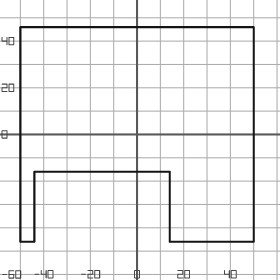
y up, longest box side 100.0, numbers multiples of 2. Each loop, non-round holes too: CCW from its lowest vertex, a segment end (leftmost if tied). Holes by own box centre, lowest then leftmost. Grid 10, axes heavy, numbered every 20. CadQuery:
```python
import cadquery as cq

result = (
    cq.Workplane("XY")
    .moveTo(-50.0, -46.0)
    .lineTo(-44.0, -46.0)
    .lineTo(-44.0, -16.0)
    .lineTo(14.0, -16.0)
    .lineTo(14.0, -46.0)
    .lineTo(50.0, -46.0)
    .lineTo(50.0, 46.0)
    .lineTo(-50.0, 46.0)
    .close()
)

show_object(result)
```